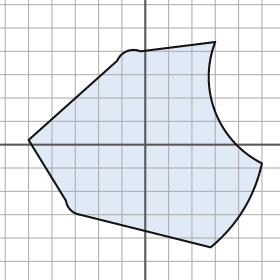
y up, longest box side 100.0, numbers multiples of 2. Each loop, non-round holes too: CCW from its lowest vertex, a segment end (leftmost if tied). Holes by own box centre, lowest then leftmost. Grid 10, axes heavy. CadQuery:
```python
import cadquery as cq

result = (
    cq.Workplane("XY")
    .moveTo(28.0, -44.0)
    .threePointArc((42.0, -28.0), (50.0, -8.0))
    .threePointArc((30.0, 14.0), (30.0, 44.0))
    .lineTo(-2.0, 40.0)
    .threePointArc((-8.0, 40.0), (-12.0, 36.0))
    .lineTo(-50.0, 2.0)
    .lineTo(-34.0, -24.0)
    .threePointArc((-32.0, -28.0), (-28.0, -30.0))
    .close()
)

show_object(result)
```